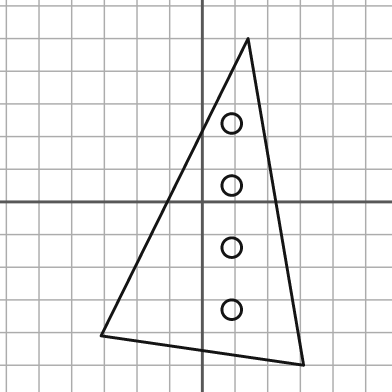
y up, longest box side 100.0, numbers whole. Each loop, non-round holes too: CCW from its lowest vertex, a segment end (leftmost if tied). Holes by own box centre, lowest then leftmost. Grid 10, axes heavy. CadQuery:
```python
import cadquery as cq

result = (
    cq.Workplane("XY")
    .moveTo(31.0, -50.0)
    .lineTo(14.0, 50.0)
    .lineTo(-31.0, -41.0)
    .close()
    .moveTo(9.0, -33.0)
    .circle(3.0)
    .moveTo(9.0, -14.0)
    .circle(3.0)
    .moveTo(9.0, 5.0)
    .circle(3.0)
    .moveTo(9.0, 24.0)
    .circle(3.0)
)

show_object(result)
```